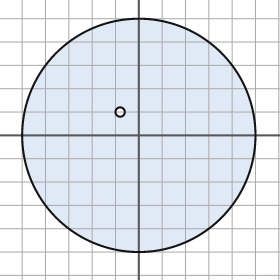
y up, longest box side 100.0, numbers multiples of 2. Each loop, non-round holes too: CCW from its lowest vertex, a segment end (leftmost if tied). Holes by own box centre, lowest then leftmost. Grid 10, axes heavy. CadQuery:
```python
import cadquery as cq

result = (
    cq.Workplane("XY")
    .moveTo(0.0, 0.0)
    .circle(50.0)
    .moveTo(-8.0, 10.0)
    .circle(2.0)
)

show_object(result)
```